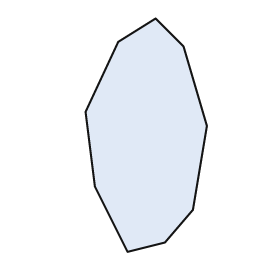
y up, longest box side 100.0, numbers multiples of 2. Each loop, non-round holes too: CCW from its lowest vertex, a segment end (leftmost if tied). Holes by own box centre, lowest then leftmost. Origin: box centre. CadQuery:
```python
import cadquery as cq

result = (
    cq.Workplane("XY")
    .moveTo(-8.0, -50.0)
    .lineTo(8.0, -46.0)
    .lineTo(20.0, -32.0)
    .lineTo(26.0, 4.0)
    .lineTo(16.0, 38.0)
    .lineTo(4.0, 50.0)
    .lineTo(-12.0, 40.0)
    .lineTo(-26.0, 10.0)
    .lineTo(-22.0, -22.0)
    .close()
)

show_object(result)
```